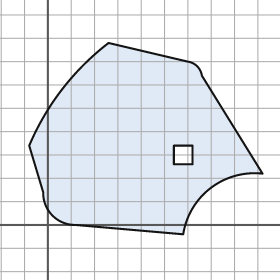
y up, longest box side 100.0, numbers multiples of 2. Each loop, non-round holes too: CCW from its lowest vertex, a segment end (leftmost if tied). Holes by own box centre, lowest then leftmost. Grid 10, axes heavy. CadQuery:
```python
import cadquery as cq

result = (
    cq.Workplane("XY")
    .moveTo(58.0, -4.0)
    .threePointArc((70.0, 16.0), (92.0, 22.0))
    .lineTo(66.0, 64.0)
    .threePointArc((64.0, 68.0), (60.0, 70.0))
    .lineTo(26.0, 78.0)
    .threePointArc((6.0, 58.0), (-8.0, 34.0))
    .lineTo(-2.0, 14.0)
    .threePointArc((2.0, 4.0), (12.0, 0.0))
    .close()
    .moveTo(54.0, 26.0)
    .lineTo(62.0, 26.0)
    .lineTo(62.0, 34.0)
    .lineTo(54.0, 34.0)
    .close()
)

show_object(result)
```